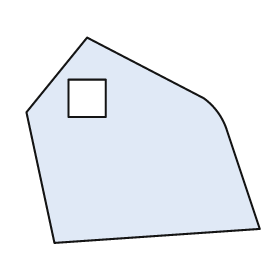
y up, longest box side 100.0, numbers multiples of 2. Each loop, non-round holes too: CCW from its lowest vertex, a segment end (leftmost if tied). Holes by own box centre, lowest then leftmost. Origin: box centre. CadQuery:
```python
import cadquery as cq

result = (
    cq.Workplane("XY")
    .moveTo(-38.0, -44.0)
    .lineTo(50.0, -38.0)
    .lineTo(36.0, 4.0)
    .threePointArc((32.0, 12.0), (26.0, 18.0))
    .lineTo(-24.0, 44.0)
    .lineTo(-50.0, 12.0)
    .close()
    .moveTo(-32.0, 10.0)
    .lineTo(-16.0, 10.0)
    .lineTo(-16.0, 26.0)
    .lineTo(-32.0, 26.0)
    .close()
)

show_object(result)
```